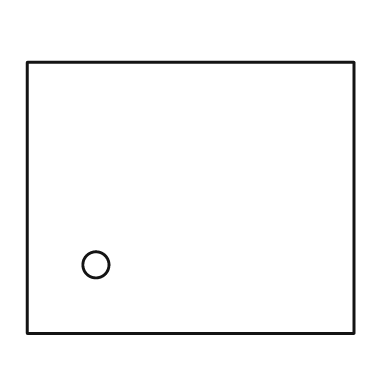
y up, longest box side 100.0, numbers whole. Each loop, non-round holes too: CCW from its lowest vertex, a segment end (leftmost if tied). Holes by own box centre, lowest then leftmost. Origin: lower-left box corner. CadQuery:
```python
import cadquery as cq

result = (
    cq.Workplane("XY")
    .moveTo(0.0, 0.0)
    .lineTo(100.0, 0.0)
    .lineTo(100.0, 83.0)
    .lineTo(0.0, 83.0)
    .close()
    .moveTo(21.0, 21.0)
    .circle(4.0)
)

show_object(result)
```